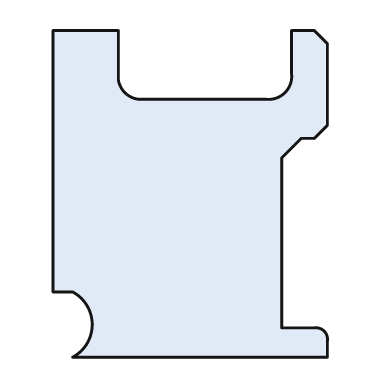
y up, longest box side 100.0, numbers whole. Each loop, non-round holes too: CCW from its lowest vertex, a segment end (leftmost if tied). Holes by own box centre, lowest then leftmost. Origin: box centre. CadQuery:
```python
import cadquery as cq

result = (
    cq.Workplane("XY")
    .moveTo(-36.0, -50.0)
    .lineTo(42.0, -50.0)
    .lineTo(42.0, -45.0)
    .threePointArc((41.0, -42.0), (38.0, -41.0))
    .lineTo(28.0, -41.0)
    .lineTo(28.0, 11.0)
    .lineTo(34.0, 17.0)
    .lineTo(38.0, 17.0)
    .lineTo(42.0, 21.0)
    .lineTo(42.0, 46.0)
    .lineTo(38.0, 50.0)
    .lineTo(31.0, 50.0)
    .lineTo(31.0, 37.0)
    .threePointArc((29.0, 31.0), (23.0, 29.0))
    .lineTo(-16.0, 29.0)
    .threePointArc((-20.0, 31.0), (-22.0, 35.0))
    .lineTo(-22.0, 50.0)
    .lineTo(-42.0, 50.0)
    .lineTo(-42.0, -30.0)
    .lineTo(-36.0, -30.0)
    .threePointArc((-30.0, -40.0), (-36.0, -50.0))
    .close()
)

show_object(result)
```